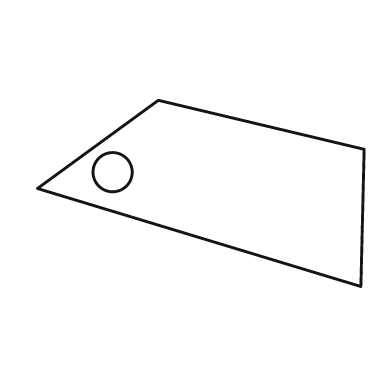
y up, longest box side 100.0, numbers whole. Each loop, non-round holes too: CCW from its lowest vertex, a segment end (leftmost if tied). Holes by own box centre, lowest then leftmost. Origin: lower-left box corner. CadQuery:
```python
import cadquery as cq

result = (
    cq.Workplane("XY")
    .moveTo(99.0, 0.0)
    .lineTo(100.0, 42.0)
    .lineTo(37.0, 57.0)
    .lineTo(0.0, 30.0)
    .close()
    .moveTo(23.0, 35.0)
    .circle(6.0)
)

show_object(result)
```